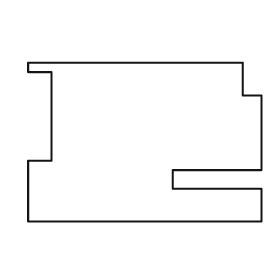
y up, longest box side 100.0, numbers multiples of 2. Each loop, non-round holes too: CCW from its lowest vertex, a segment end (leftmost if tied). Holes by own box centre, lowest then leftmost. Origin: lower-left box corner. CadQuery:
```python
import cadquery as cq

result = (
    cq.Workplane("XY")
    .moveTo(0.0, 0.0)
    .lineTo(100.0, 0.0)
    .lineTo(100.0, 14.0)
    .lineTo(62.0, 14.0)
    .lineTo(62.0, 22.0)
    .lineTo(100.0, 22.0)
    .lineTo(100.0, 54.0)
    .lineTo(92.0, 54.0)
    .lineTo(92.0, 68.0)
    .lineTo(0.0, 68.0)
    .lineTo(0.0, 64.0)
    .lineTo(10.0, 64.0)
    .lineTo(10.0, 26.0)
    .lineTo(0.0, 26.0)
    .close()
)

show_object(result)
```